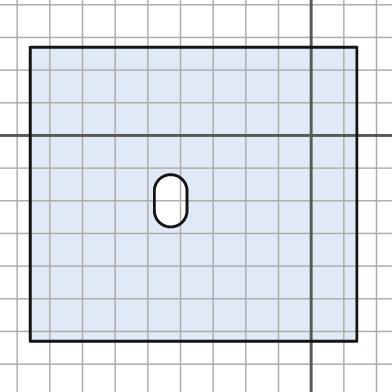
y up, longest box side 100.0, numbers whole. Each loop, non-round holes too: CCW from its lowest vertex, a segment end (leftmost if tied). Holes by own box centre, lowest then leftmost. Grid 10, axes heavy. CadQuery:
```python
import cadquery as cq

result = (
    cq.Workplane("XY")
    .moveTo(-86.0, -63.0)
    .lineTo(14.0, -63.0)
    .lineTo(14.0, 27.0)
    .lineTo(-86.0, 27.0)
    .close()
    .moveTo(-48.0, -23.0)
    .threePointArc((-43.0, -28.0), (-38.0, -23.0))
    .lineTo(-38.0, -17.0)
    .threePointArc((-43.0, -12.0), (-48.0, -17.0))
    .close()
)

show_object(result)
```